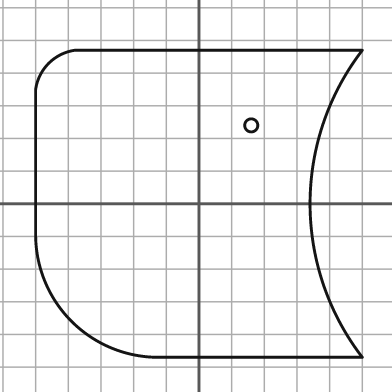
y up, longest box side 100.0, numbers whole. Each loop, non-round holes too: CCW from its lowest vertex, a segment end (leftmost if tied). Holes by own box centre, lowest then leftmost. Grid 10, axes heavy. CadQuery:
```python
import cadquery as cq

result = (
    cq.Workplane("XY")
    .moveTo(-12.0, -47.0)
    .lineTo(50.0, -47.0)
    .threePointArc((34.0, 0.0), (50.0, 47.0))
    .lineTo(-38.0, 47.0)
    .threePointArc((-46.0, 43.0), (-50.0, 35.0))
    .lineTo(-50.0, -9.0)
    .threePointArc((-39.0, -36.0), (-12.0, -47.0))
    .close()
    .moveTo(16.0, 24.0)
    .circle(2.0)
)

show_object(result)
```